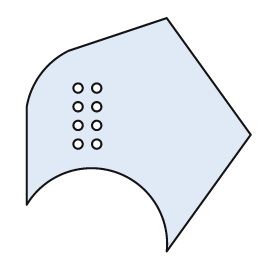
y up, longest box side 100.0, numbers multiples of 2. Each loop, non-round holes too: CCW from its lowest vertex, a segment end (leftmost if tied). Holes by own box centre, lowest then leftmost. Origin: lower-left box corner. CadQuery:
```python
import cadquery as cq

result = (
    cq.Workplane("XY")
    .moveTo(60.0, 0.0)
    .lineTo(96.0, 50.0)
    .lineTo(60.0, 100.0)
    .lineTo(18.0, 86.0)
    .threePointArc((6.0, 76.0), (0.0, 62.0))
    .lineTo(0.0, 20.0)
    .threePointArc((38.0, 34.0), (60.0, 0.0))
    .close()
    .moveTo(22.0, 46.0)
    .circle(2.0)
    .moveTo(30.0, 46.0)
    .circle(2.0)
    .moveTo(22.0, 54.0)
    .circle(2.0)
    .moveTo(30.0, 54.0)
    .circle(2.0)
    .moveTo(22.0, 62.0)
    .circle(2.0)
    .moveTo(30.0, 62.0)
    .circle(2.0)
    .moveTo(22.0, 70.0)
    .circle(2.0)
    .moveTo(30.0, 70.0)
    .circle(2.0)
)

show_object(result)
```